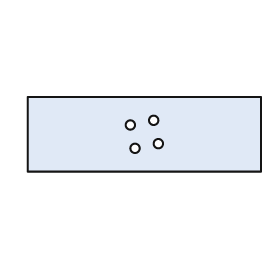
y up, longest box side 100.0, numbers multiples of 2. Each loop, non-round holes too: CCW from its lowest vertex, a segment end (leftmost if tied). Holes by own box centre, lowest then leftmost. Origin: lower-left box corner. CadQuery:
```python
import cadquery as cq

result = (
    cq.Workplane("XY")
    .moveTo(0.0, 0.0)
    .lineTo(100.0, 0.0)
    .lineTo(100.0, 32.0)
    .lineTo(0.0, 32.0)
    .close()
    .moveTo(46.0, 10.0)
    .circle(2.0)
    .moveTo(56.0, 12.0)
    .circle(2.0)
    .moveTo(44.0, 20.0)
    .circle(2.0)
    .moveTo(54.0, 22.0)
    .circle(2.0)
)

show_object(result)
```